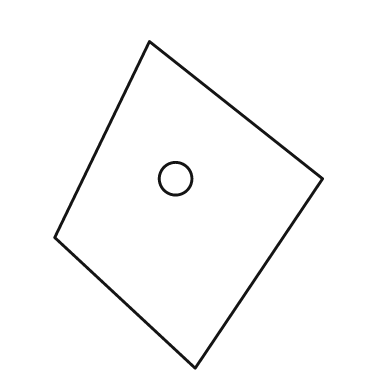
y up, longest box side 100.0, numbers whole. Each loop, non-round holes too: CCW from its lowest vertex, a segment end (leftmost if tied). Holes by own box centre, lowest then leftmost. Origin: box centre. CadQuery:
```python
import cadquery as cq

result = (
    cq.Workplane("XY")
    .moveTo(2.0, -50.0)
    .lineTo(41.0, 8.0)
    .lineTo(-12.0, 50.0)
    .lineTo(-41.0, -10.0)
    .close()
    .moveTo(-4.0, 8.0)
    .circle(5.0)
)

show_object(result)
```